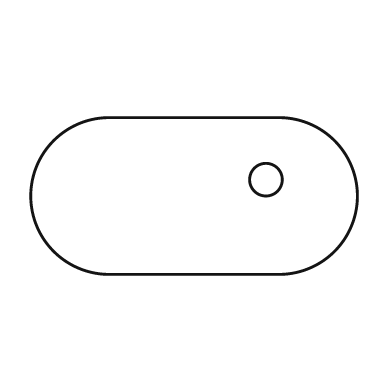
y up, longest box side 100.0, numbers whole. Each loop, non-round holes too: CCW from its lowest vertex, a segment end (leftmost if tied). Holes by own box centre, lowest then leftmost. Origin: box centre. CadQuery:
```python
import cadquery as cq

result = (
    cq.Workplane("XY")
    .moveTo(-26.0, -24.0)
    .lineTo(26.0, -24.0)
    .threePointArc((50.0, 0.0), (26.0, 24.0))
    .lineTo(-26.0, 24.0)
    .threePointArc((-50.0, 0.0), (-26.0, -24.0))
    .close()
    .moveTo(22.0, 5.0)
    .circle(5.0)
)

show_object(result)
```